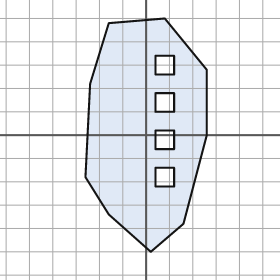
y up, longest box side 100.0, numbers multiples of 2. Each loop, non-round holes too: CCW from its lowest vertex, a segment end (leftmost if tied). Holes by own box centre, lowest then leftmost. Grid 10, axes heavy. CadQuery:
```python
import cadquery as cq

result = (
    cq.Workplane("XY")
    .moveTo(2.0, -50.0)
    .lineTo(16.0, -38.0)
    .lineTo(26.0, 0.0)
    .lineTo(26.0, 28.0)
    .lineTo(8.0, 50.0)
    .lineTo(-16.0, 48.0)
    .lineTo(-24.0, 22.0)
    .lineTo(-26.0, -18.0)
    .lineTo(-16.0, -34.0)
    .close()
    .moveTo(4.0, -22.0)
    .lineTo(12.0, -22.0)
    .lineTo(12.0, -14.0)
    .lineTo(4.0, -14.0)
    .close()
    .moveTo(4.0, -6.0)
    .lineTo(12.0, -6.0)
    .lineTo(12.0, 2.0)
    .lineTo(4.0, 2.0)
    .close()
    .moveTo(4.0, 10.0)
    .lineTo(12.0, 10.0)
    .lineTo(12.0, 18.0)
    .lineTo(4.0, 18.0)
    .close()
    .moveTo(4.0, 26.0)
    .lineTo(12.0, 26.0)
    .lineTo(12.0, 34.0)
    .lineTo(4.0, 34.0)
    .close()
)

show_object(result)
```